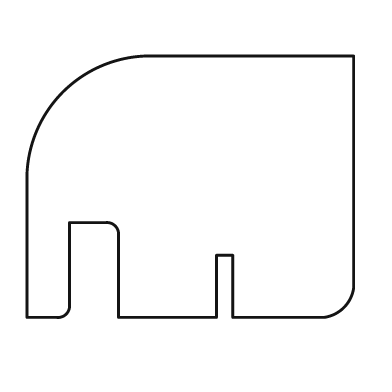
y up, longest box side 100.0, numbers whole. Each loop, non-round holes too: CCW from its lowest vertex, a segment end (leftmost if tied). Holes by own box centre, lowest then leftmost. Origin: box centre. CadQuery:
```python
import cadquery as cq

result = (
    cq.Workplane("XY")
    .moveTo(-50.0, -40.0)
    .lineTo(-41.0, -40.0)
    .threePointArc((-38.0, -39.0), (-37.0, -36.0))
    .lineTo(-37.0, -11.0)
    .lineTo(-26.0, -11.0)
    .threePointArc((-23.0, -12.0), (-22.0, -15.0))
    .lineTo(-22.0, -40.0)
    .lineTo(8.0, -40.0)
    .lineTo(8.0, -21.0)
    .lineTo(13.0, -21.0)
    .lineTo(13.0, -40.0)
    .lineTo(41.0, -40.0)
    .threePointArc((47.0, -37.0), (50.0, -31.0))
    .lineTo(50.0, 40.0)
    .lineTo(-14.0, 40.0)
    .threePointArc((-39.0, 29.0), (-50.0, 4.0))
    .close()
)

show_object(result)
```